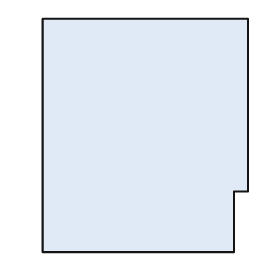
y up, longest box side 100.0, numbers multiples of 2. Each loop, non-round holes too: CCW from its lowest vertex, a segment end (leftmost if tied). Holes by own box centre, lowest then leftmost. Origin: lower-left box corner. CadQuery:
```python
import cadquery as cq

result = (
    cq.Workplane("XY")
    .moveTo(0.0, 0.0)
    .lineTo(82.0, 0.0)
    .lineTo(82.0, 26.0)
    .lineTo(88.0, 26.0)
    .lineTo(88.0, 100.0)
    .lineTo(0.0, 100.0)
    .close()
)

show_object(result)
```